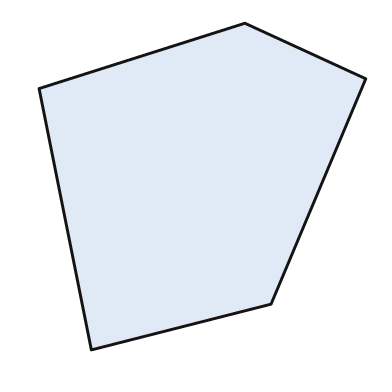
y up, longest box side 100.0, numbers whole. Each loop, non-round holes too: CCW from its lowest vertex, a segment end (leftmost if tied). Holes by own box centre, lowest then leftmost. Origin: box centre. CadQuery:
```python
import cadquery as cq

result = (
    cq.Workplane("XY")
    .moveTo(-34.0, -50.0)
    .lineTo(21.0, -36.0)
    .lineTo(50.0, 33.0)
    .lineTo(13.0, 50.0)
    .lineTo(-50.0, 30.0)
    .close()
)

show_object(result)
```